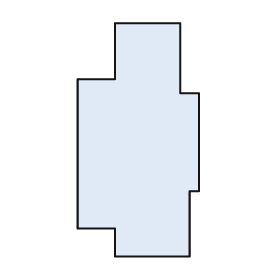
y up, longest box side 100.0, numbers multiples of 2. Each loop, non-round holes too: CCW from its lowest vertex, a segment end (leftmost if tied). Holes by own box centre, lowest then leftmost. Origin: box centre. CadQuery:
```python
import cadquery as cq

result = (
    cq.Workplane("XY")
    .moveTo(-10.0, -50.0)
    .lineTo(22.0, -50.0)
    .lineTo(22.0, -22.0)
    .lineTo(26.0, -22.0)
    .lineTo(26.0, 20.0)
    .lineTo(18.0, 20.0)
    .lineTo(18.0, 50.0)
    .lineTo(-10.0, 50.0)
    .lineTo(-10.0, 26.0)
    .lineTo(-26.0, 26.0)
    .lineTo(-26.0, -38.0)
    .lineTo(-10.0, -38.0)
    .close()
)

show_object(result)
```